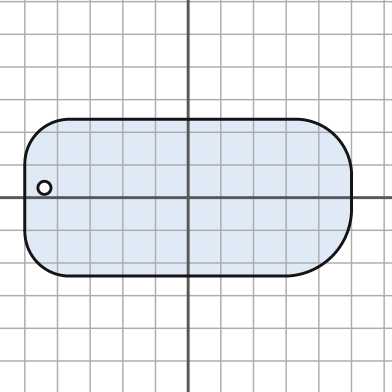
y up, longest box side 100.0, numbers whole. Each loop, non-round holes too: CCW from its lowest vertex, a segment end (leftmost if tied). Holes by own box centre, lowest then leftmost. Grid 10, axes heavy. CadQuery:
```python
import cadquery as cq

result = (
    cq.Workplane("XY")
    .moveTo(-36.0, -24.0)
    .lineTo(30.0, -24.0)
    .threePointArc((44.0, -18.0), (50.0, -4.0))
    .lineTo(50.0, 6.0)
    .threePointArc((45.0, 19.0), (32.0, 24.0))
    .lineTo(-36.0, 24.0)
    .threePointArc((-46.0, 20.0), (-50.0, 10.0))
    .lineTo(-50.0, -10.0)
    .threePointArc((-46.0, -20.0), (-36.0, -24.0))
    .close()
    .moveTo(-44.0, 3.0)
    .circle(2.0)
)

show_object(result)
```